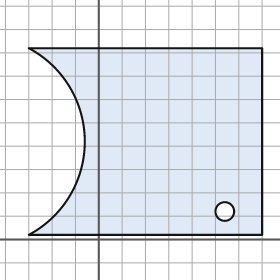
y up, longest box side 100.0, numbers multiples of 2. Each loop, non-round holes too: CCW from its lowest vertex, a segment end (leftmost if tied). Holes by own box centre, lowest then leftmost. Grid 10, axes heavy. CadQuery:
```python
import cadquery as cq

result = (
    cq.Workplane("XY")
    .moveTo(-30.0, 2.0)
    .lineTo(70.0, 2.0)
    .lineTo(70.0, 82.0)
    .lineTo(-30.0, 82.0)
    .threePointArc((-6.0, 42.0), (-30.0, 2.0))
    .close()
    .moveTo(54.0, 12.0)
    .circle(4.0)
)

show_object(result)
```